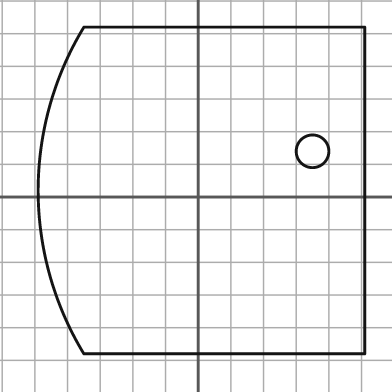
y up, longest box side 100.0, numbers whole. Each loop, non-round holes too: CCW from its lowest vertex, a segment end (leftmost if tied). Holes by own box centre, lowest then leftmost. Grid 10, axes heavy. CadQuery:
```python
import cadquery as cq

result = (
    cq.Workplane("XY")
    .moveTo(-35.0, -48.0)
    .lineTo(51.0, -48.0)
    .lineTo(51.0, 52.0)
    .lineTo(-35.0, 52.0)
    .threePointArc((-49.0, 2.0), (-35.0, -48.0))
    .close()
    .moveTo(35.0, 14.0)
    .circle(5.0)
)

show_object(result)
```